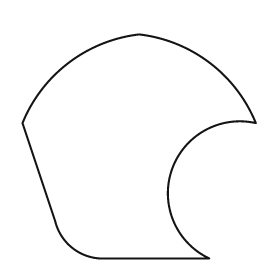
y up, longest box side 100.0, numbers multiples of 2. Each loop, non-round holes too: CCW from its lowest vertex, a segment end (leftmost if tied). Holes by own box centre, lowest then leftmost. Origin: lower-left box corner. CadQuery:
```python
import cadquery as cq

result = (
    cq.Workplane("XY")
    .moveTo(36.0, 0.0)
    .lineTo(80.0, 0.0)
    .threePointArc((64.0, 38.0), (100.0, 58.0))
    .threePointArc((80.0, 84.0), (50.0, 96.0))
    .threePointArc((20.0, 84.0), (0.0, 58.0))
    .lineTo(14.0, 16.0)
    .threePointArc((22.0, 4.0), (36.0, 0.0))
    .close()
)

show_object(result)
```